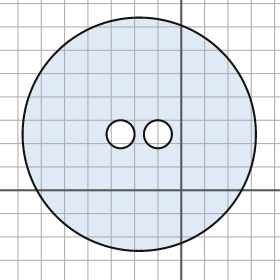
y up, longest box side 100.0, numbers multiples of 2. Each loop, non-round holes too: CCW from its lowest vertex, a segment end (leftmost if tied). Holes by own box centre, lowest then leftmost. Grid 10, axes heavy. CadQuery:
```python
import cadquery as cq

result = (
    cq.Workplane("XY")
    .moveTo(-18.0, 24.0)
    .circle(50.0)
    .moveTo(-26.0, 24.0)
    .circle(6.0)
    .moveTo(-10.0, 24.0)
    .circle(6.0)
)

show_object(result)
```